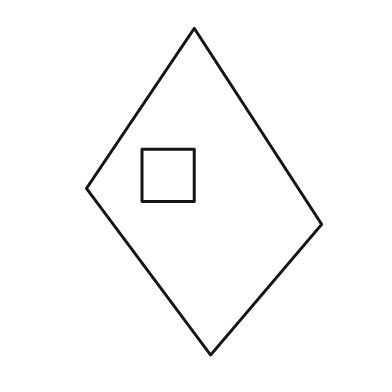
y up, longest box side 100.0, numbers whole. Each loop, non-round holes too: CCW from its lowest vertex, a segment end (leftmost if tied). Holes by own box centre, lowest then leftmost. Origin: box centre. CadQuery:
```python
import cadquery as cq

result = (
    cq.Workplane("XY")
    .moveTo(2.0, -50.0)
    .lineTo(36.0, -10.0)
    .lineTo(-3.0, 50.0)
    .lineTo(-36.0, 1.0)
    .close()
    .moveTo(-19.0, -3.0)
    .lineTo(-3.0, -3.0)
    .lineTo(-3.0, 13.0)
    .lineTo(-19.0, 13.0)
    .close()
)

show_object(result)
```